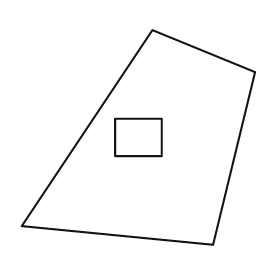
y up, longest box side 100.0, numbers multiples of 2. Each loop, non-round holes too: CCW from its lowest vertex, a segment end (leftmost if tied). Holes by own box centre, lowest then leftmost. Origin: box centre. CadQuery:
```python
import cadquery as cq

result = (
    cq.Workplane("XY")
    .moveTo(32.0, -46.0)
    .lineTo(50.0, 28.0)
    .lineTo(6.0, 46.0)
    .lineTo(-50.0, -38.0)
    .close()
    .moveTo(-10.0, -8.0)
    .lineTo(10.0, -8.0)
    .lineTo(10.0, 8.0)
    .lineTo(-10.0, 8.0)
    .close()
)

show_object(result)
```